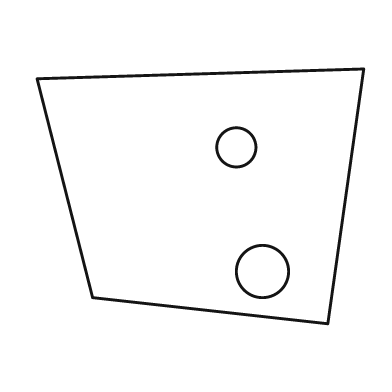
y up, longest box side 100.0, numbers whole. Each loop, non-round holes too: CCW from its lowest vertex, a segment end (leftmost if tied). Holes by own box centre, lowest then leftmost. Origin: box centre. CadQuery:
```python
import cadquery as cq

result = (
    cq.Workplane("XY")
    .moveTo(39.0, -39.0)
    .lineTo(50.0, 39.0)
    .lineTo(-50.0, 36.0)
    .lineTo(-33.0, -31.0)
    .close()
    .moveTo(19.0, -23.0)
    .circle(8.0)
    .moveTo(11.0, 15.0)
    .circle(6.0)
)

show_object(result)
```